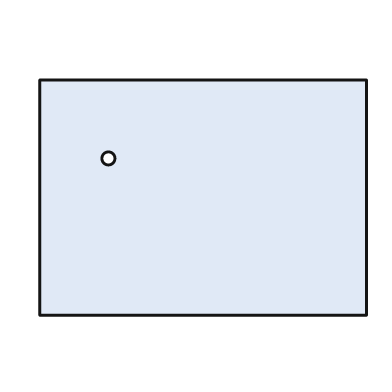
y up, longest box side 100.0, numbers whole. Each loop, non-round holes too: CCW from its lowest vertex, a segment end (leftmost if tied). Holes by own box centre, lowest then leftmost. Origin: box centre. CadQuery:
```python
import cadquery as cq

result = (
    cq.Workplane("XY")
    .moveTo(-50.0, -36.0)
    .lineTo(50.0, -36.0)
    .lineTo(50.0, 36.0)
    .lineTo(-50.0, 36.0)
    .close()
    .moveTo(-29.0, 12.0)
    .circle(2.0)
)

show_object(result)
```